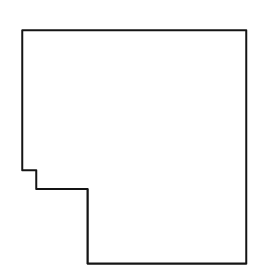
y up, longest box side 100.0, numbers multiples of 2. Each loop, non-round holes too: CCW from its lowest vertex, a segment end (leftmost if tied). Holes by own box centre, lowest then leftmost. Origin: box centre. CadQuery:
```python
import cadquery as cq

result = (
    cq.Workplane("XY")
    .moveTo(-20.0, -50.0)
    .lineTo(48.0, -50.0)
    .lineTo(48.0, 50.0)
    .lineTo(-48.0, 50.0)
    .lineTo(-48.0, -10.0)
    .lineTo(-42.0, -10.0)
    .lineTo(-42.0, -18.0)
    .lineTo(-20.0, -18.0)
    .close()
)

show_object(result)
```